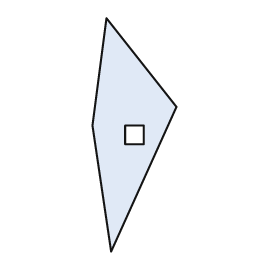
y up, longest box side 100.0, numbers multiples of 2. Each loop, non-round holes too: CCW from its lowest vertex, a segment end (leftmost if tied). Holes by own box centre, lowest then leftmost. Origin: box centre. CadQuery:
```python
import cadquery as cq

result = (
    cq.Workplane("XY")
    .moveTo(-10.0, -50.0)
    .lineTo(18.0, 12.0)
    .lineTo(-12.0, 50.0)
    .lineTo(-18.0, 4.0)
    .close()
    .moveTo(-4.0, -4.0)
    .lineTo(4.0, -4.0)
    .lineTo(4.0, 4.0)
    .lineTo(-4.0, 4.0)
    .close()
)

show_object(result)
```